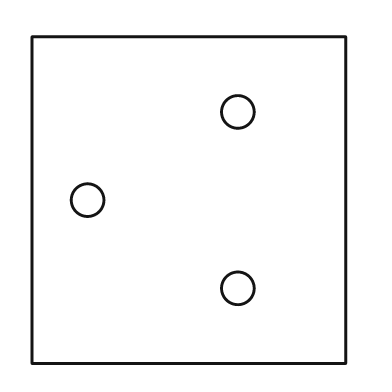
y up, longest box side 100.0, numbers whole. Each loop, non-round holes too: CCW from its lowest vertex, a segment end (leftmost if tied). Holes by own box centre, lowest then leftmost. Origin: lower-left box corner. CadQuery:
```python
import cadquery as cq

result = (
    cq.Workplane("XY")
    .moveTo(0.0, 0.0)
    .lineTo(96.0, 0.0)
    .lineTo(96.0, 100.0)
    .lineTo(0.0, 100.0)
    .close()
    .moveTo(63.0, 23.0)
    .circle(5.0)
    .moveTo(17.0, 50.0)
    .circle(5.0)
    .moveTo(63.0, 77.0)
    .circle(5.0)
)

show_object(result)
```